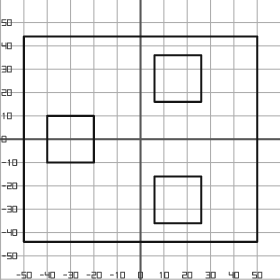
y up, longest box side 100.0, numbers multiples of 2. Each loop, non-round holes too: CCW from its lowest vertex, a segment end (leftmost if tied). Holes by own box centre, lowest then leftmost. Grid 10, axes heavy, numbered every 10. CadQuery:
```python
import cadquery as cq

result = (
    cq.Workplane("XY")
    .moveTo(-50.0, -44.0)
    .lineTo(50.0, -44.0)
    .lineTo(50.0, 44.0)
    .lineTo(-50.0, 44.0)
    .close()
    .moveTo(6.0, -36.0)
    .lineTo(26.0, -36.0)
    .lineTo(26.0, -16.0)
    .lineTo(6.0, -16.0)
    .close()
    .moveTo(-40.0, -10.0)
    .lineTo(-20.0, -10.0)
    .lineTo(-20.0, 10.0)
    .lineTo(-40.0, 10.0)
    .close()
    .moveTo(6.0, 16.0)
    .lineTo(26.0, 16.0)
    .lineTo(26.0, 36.0)
    .lineTo(6.0, 36.0)
    .close()
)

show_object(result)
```